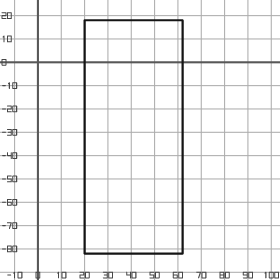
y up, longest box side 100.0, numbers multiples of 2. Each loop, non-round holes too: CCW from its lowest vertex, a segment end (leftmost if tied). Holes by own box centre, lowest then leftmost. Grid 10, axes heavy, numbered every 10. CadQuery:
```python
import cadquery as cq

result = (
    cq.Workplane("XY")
    .moveTo(20.0, -82.0)
    .lineTo(62.0, -82.0)
    .lineTo(62.0, 18.0)
    .lineTo(20.0, 18.0)
    .close()
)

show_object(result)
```